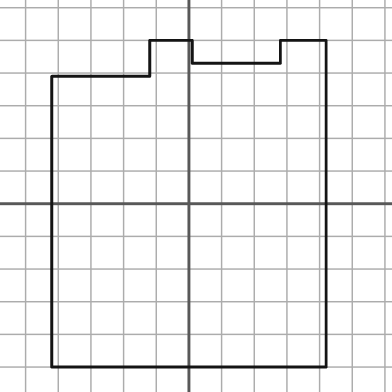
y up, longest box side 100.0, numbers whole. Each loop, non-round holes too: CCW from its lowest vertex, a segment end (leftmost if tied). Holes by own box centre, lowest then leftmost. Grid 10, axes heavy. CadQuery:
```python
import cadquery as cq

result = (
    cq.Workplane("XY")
    .moveTo(-42.0, -50.0)
    .lineTo(42.0, -50.0)
    .lineTo(42.0, 50.0)
    .lineTo(28.0, 50.0)
    .lineTo(28.0, 43.0)
    .lineTo(1.0, 43.0)
    .lineTo(1.0, 50.0)
    .lineTo(-12.0, 50.0)
    .lineTo(-12.0, 39.0)
    .lineTo(-42.0, 39.0)
    .close()
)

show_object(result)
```